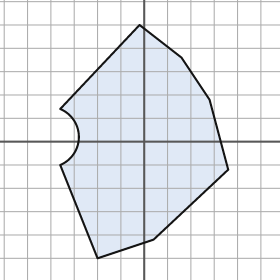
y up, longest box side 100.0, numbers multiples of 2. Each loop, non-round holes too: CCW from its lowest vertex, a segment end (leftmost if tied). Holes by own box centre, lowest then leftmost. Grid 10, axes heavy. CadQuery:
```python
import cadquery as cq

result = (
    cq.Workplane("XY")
    .moveTo(-20.0, -50.0)
    .lineTo(4.0, -42.0)
    .lineTo(36.0, -12.0)
    .lineTo(28.0, 18.0)
    .lineTo(16.0, 36.0)
    .lineTo(-2.0, 50.0)
    .lineTo(-36.0, 14.0)
    .threePointArc((-28.0, 2.0), (-36.0, -10.0))
    .close()
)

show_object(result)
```